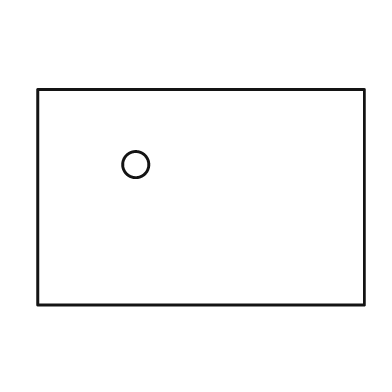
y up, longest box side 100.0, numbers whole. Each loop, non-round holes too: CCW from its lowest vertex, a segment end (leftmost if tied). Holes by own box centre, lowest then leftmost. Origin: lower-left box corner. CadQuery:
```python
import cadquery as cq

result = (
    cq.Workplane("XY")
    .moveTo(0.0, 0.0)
    .lineTo(100.0, 0.0)
    .lineTo(100.0, 66.0)
    .lineTo(0.0, 66.0)
    .close()
    .moveTo(30.0, 43.0)
    .circle(4.0)
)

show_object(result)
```